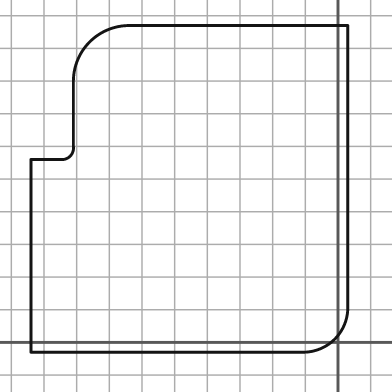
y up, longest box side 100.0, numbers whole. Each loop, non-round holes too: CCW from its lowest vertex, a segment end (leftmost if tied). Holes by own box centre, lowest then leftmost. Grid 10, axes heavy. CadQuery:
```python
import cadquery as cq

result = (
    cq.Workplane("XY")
    .moveTo(-94.0, -3.0)
    .lineTo(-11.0, -3.0)
    .threePointArc((-1.0, 1.0), (3.0, 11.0))
    .lineTo(3.0, 97.0)
    .lineTo(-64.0, 97.0)
    .threePointArc((-76.0, 92.0), (-81.0, 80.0))
    .lineTo(-81.0, 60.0)
    .threePointArc((-82.0, 57.0), (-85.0, 56.0))
    .lineTo(-94.0, 56.0)
    .close()
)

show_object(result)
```